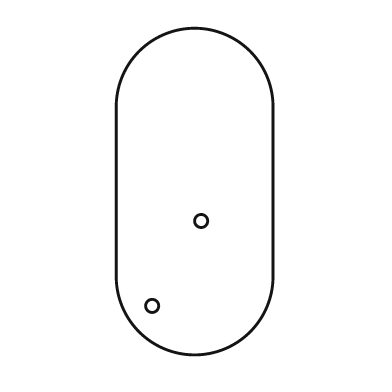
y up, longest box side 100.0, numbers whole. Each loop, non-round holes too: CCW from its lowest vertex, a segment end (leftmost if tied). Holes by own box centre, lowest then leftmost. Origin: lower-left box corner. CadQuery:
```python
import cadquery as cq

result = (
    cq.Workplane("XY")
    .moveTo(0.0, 24.0)
    .threePointArc((24.0, 0.0), (48.0, 24.0))
    .lineTo(48.0, 76.0)
    .threePointArc((24.0, 100.0), (0.0, 76.0))
    .close()
    .moveTo(11.0, 15.0)
    .circle(2.0)
    .moveTo(26.0, 41.0)
    .circle(2.0)
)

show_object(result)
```